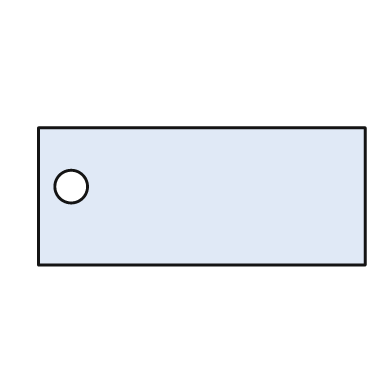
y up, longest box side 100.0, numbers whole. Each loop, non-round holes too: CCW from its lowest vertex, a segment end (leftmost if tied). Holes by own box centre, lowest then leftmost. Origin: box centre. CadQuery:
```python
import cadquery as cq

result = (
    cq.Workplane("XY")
    .moveTo(-50.0, -21.0)
    .lineTo(50.0, -21.0)
    .lineTo(50.0, 21.0)
    .lineTo(-50.0, 21.0)
    .close()
    .moveTo(-40.0, 3.0)
    .circle(5.0)
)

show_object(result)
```